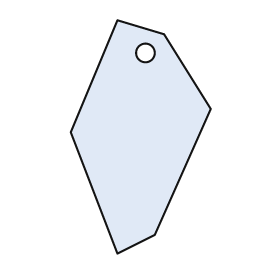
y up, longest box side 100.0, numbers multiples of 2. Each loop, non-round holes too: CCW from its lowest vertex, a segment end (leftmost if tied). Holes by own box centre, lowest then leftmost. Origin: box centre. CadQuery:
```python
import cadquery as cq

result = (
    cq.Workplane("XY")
    .moveTo(-10.0, -50.0)
    .lineTo(6.0, -42.0)
    .lineTo(30.0, 12.0)
    .lineTo(10.0, 44.0)
    .lineTo(-10.0, 50.0)
    .lineTo(-30.0, 2.0)
    .close()
    .moveTo(2.0, 36.0)
    .circle(4.0)
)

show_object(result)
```